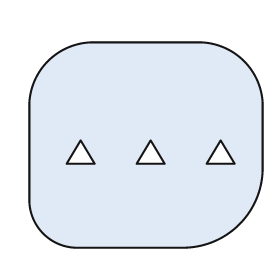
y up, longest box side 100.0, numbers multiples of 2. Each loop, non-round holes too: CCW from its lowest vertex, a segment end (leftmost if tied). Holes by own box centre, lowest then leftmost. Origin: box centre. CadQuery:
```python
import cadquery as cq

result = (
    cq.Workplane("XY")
    .moveTo(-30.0, -44.0)
    .lineTo(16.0, -44.0)
    .threePointArc((40.0, -34.0), (50.0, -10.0))
    .lineTo(50.0, 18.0)
    .threePointArc((42.0, 36.0), (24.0, 44.0))
    .lineTo(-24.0, 44.0)
    .threePointArc((-42.0, 36.0), (-50.0, 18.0))
    .lineTo(-50.0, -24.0)
    .threePointArc((-44.0, -38.0), (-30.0, -44.0))
    .close()
    .moveTo(-34.0, -8.0)
    .lineTo(-22.0, -8.0)
    .lineTo(-28.0, 2.0)
    .close()
    .moveTo(-4.0, -8.0)
    .lineTo(8.0, -8.0)
    .lineTo(2.0, 2.0)
    .close()
    .moveTo(26.0, -8.0)
    .lineTo(38.0, -8.0)
    .lineTo(32.0, 2.0)
    .close()
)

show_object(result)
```